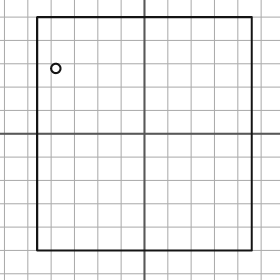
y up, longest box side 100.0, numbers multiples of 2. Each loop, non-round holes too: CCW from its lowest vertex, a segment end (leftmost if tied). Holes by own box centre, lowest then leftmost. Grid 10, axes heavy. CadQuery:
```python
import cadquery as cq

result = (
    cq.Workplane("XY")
    .moveTo(-46.0, -50.0)
    .lineTo(46.0, -50.0)
    .lineTo(46.0, 50.0)
    .lineTo(-46.0, 50.0)
    .close()
    .moveTo(-38.0, 28.0)
    .circle(2.0)
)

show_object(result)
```